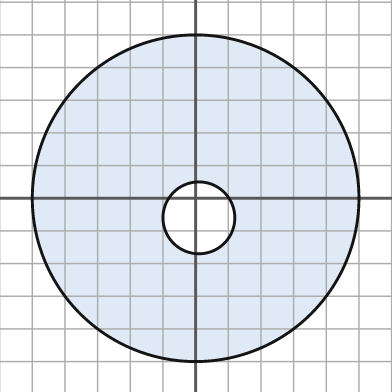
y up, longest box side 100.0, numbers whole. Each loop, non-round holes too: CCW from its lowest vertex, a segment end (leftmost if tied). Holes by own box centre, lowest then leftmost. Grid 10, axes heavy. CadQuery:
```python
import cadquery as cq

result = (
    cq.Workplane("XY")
    .moveTo(0.0, 0.0)
    .circle(50.0)
    .moveTo(1.0, -6.0)
    .circle(11.0)
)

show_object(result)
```